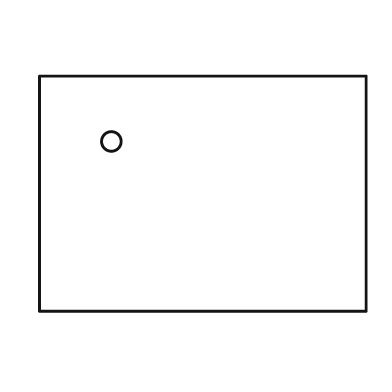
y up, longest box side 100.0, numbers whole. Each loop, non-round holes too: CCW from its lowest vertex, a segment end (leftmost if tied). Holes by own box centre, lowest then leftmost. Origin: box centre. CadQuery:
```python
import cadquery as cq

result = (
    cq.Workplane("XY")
    .moveTo(-50.0, -36.0)
    .lineTo(50.0, -36.0)
    .lineTo(50.0, 36.0)
    .lineTo(-50.0, 36.0)
    .close()
    .moveTo(-28.0, 16.0)
    .circle(3.0)
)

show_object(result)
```